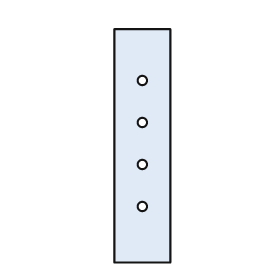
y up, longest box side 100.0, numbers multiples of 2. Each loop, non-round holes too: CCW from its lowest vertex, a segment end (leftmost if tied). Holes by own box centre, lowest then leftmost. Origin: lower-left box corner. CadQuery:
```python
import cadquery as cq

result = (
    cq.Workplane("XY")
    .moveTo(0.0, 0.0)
    .lineTo(24.0, 0.0)
    .lineTo(24.0, 100.0)
    .lineTo(0.0, 100.0)
    .close()
    .moveTo(12.0, 24.0)
    .circle(2.0)
    .moveTo(12.0, 42.0)
    .circle(2.0)
    .moveTo(12.0, 60.0)
    .circle(2.0)
    .moveTo(12.0, 78.0)
    .circle(2.0)
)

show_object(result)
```